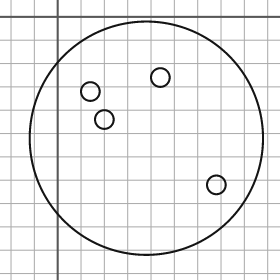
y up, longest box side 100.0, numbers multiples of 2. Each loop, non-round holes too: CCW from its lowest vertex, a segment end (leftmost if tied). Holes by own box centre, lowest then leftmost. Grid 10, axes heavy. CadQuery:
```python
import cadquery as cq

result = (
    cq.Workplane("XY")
    .moveTo(38.0, -52.0)
    .circle(50.0)
    .moveTo(68.0, -72.0)
    .circle(4.0)
    .moveTo(20.0, -44.0)
    .circle(4.0)
    .moveTo(14.0, -32.0)
    .circle(4.0)
    .moveTo(44.0, -26.0)
    .circle(4.0)
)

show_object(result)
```